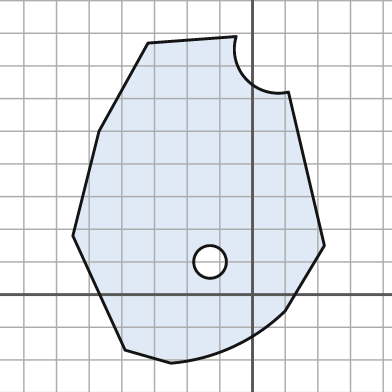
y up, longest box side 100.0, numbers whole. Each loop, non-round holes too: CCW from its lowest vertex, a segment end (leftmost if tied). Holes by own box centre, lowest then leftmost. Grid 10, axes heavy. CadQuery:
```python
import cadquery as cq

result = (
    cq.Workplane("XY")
    .moveTo(-25.0, -21.0)
    .threePointArc((-6.0, -16.0), (10.0, -5.0))
    .lineTo(22.0, 15.0)
    .lineTo(11.0, 62.0)
    .threePointArc((-2.0, 66.0), (-5.0, 79.0))
    .lineTo(-32.0, 77.0)
    .lineTo(-47.0, 50.0)
    .lineTo(-55.0, 18.0)
    .lineTo(-39.0, -17.0)
    .close()
    .moveTo(-13.0, 10.0)
    .circle(5.0)
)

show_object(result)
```